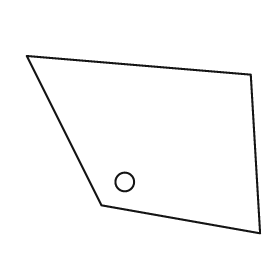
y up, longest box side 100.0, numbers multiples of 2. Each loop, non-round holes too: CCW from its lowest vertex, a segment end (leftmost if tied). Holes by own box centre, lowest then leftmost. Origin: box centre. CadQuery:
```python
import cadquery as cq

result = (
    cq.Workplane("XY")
    .moveTo(50.0, -38.0)
    .lineTo(46.0, 30.0)
    .lineTo(-50.0, 38.0)
    .lineTo(-18.0, -26.0)
    .close()
    .moveTo(-8.0, -16.0)
    .circle(4.0)
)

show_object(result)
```